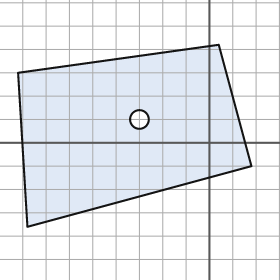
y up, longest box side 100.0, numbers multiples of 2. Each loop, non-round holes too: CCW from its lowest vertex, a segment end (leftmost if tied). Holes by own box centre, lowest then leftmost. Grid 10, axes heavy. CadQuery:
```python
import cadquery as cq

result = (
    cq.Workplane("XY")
    .moveTo(-78.0, -36.0)
    .lineTo(18.0, -10.0)
    .lineTo(4.0, 42.0)
    .lineTo(-82.0, 30.0)
    .close()
    .moveTo(-30.0, 10.0)
    .circle(4.0)
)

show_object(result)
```